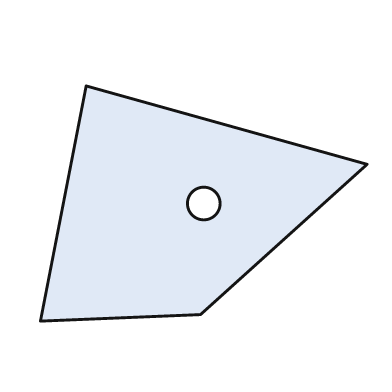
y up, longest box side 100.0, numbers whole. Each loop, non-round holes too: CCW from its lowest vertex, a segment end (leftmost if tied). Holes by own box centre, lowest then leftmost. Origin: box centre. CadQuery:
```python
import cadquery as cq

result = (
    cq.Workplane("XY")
    .moveTo(-50.0, -36.0)
    .lineTo(-1.0, -34.0)
    .lineTo(50.0, 12.0)
    .lineTo(-36.0, 36.0)
    .close()
    .moveTo(0.0, 0.0)
    .circle(5.0)
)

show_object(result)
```